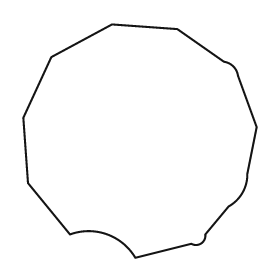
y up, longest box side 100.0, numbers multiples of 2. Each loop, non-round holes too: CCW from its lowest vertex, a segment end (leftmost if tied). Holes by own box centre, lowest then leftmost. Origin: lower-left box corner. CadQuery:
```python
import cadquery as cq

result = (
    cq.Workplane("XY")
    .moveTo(48.0, 0.0)
    .lineTo(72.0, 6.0)
    .threePointArc((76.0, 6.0), (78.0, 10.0))
    .lineTo(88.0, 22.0)
    .threePointArc((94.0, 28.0), (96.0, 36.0))
    .lineTo(100.0, 56.0)
    .lineTo(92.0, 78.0)
    .threePointArc((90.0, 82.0), (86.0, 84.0))
    .lineTo(66.0, 98.0)
    .lineTo(38.0, 100.0)
    .lineTo(12.0, 86.0)
    .lineTo(0.0, 60.0)
    .lineTo(2.0, 32.0)
    .lineTo(20.0, 10.0)
    .threePointArc((36.0, 10.0), (48.0, 0.0))
    .close()
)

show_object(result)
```